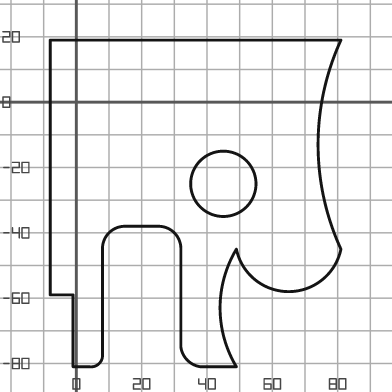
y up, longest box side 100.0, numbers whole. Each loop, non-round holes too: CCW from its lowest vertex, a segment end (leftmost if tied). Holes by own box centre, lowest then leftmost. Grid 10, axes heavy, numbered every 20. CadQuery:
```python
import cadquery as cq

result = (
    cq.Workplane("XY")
    .moveTo(-1.0, -81.0)
    .lineTo(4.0, -81.0)
    .threePointArc((7.0, -80.0), (8.0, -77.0))
    .lineTo(8.0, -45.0)
    .threePointArc((10.0, -40.0), (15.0, -38.0))
    .lineTo(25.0, -38.0)
    .threePointArc((30.0, -40.0), (32.0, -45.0))
    .lineTo(32.0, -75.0)
    .threePointArc((34.0, -79.0), (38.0, -81.0))
    .lineTo(49.0, -81.0)
    .threePointArc((44.0, -63.0), (49.0, -45.0))
    .threePointArc((65.0, -58.0), (81.0, -45.0))
    .threePointArc((74.0, -13.0), (81.0, 19.0))
    .lineTo(-8.0, 19.0)
    .lineTo(-8.0, -59.0)
    .lineTo(-1.0, -59.0)
    .close()
    .moveTo(45.0, -25.0)
    .circle(10.0)
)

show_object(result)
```